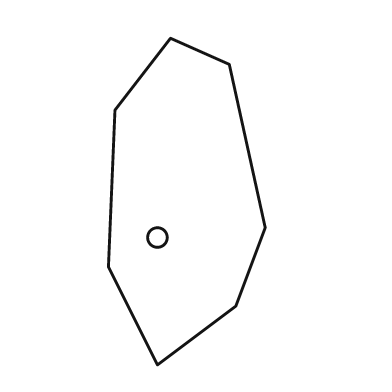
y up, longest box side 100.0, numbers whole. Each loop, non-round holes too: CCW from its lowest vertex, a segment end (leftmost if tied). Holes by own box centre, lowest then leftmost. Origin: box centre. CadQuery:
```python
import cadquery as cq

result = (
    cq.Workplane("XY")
    .moveTo(-9.0, -50.0)
    .lineTo(15.0, -32.0)
    .lineTo(24.0, -8.0)
    .lineTo(13.0, 42.0)
    .lineTo(-5.0, 50.0)
    .lineTo(-22.0, 28.0)
    .lineTo(-24.0, -20.0)
    .close()
    .moveTo(-9.0, -11.0)
    .circle(3.0)
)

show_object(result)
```